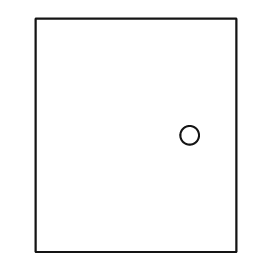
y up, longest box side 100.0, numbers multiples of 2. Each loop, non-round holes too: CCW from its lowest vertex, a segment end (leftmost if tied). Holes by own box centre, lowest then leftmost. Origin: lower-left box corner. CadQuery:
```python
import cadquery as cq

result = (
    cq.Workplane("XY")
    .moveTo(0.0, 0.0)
    .lineTo(86.0, 0.0)
    .lineTo(86.0, 100.0)
    .lineTo(0.0, 100.0)
    .close()
    .moveTo(66.0, 50.0)
    .circle(4.0)
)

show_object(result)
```